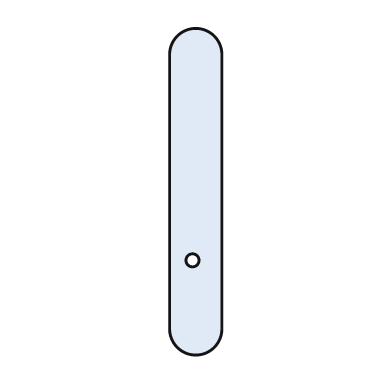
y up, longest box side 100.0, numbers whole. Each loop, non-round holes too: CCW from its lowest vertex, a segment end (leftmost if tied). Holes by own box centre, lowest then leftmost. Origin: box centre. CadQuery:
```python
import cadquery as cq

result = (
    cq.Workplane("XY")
    .moveTo(-8.0, -42.0)
    .threePointArc((0.0, -50.0), (8.0, -42.0))
    .lineTo(8.0, 42.0)
    .threePointArc((0.0, 50.0), (-8.0, 42.0))
    .close()
    .moveTo(-1.0, -21.0)
    .circle(2.0)
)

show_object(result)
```